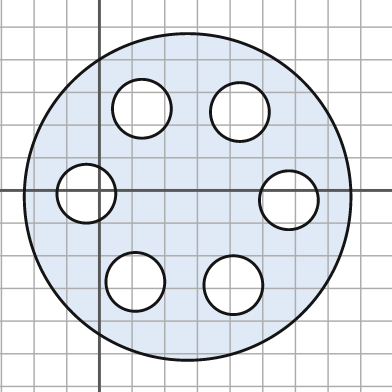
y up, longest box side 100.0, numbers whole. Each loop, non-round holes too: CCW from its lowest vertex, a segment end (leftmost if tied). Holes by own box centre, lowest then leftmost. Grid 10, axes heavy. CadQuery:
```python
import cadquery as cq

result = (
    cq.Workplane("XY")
    .moveTo(27.0, -2.0)
    .circle(50.0)
    .moveTo(41.0, -29.0)
    .circle(9.0)
    .moveTo(11.0, -28.0)
    .circle(9.0)
    .moveTo(58.0, -3.0)
    .circle(9.0)
    .moveTo(-4.0, -1.0)
    .circle(9.0)
    .moveTo(43.0, 24.0)
    .circle(9.0)
    .moveTo(13.0, 25.0)
    .circle(9.0)
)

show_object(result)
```